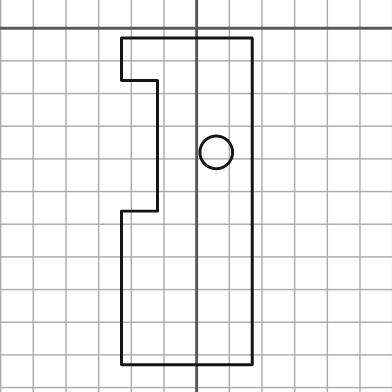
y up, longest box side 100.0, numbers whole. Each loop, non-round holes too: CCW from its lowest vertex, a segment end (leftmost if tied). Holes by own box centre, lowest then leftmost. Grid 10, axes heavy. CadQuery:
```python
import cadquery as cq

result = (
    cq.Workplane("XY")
    .moveTo(-23.0, -103.0)
    .lineTo(17.0, -103.0)
    .lineTo(17.0, -3.0)
    .lineTo(-23.0, -3.0)
    .lineTo(-23.0, -16.0)
    .lineTo(-12.0, -16.0)
    .lineTo(-12.0, -56.0)
    .lineTo(-23.0, -56.0)
    .close()
    .moveTo(6.0, -38.0)
    .circle(5.0)
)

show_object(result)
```